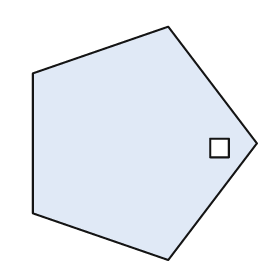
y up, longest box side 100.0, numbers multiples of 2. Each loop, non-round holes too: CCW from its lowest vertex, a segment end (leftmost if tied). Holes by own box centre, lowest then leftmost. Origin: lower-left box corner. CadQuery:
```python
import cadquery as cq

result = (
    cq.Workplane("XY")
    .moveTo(58.0, 0.0)
    .lineTo(96.0, 50.0)
    .lineTo(58.0, 100.0)
    .lineTo(0.0, 80.0)
    .lineTo(0.0, 20.0)
    .close()
    .moveTo(76.0, 44.0)
    .lineTo(84.0, 44.0)
    .lineTo(84.0, 52.0)
    .lineTo(76.0, 52.0)
    .close()
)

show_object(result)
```